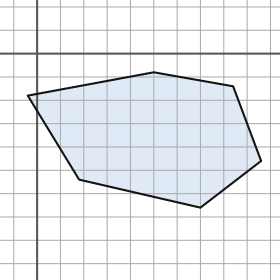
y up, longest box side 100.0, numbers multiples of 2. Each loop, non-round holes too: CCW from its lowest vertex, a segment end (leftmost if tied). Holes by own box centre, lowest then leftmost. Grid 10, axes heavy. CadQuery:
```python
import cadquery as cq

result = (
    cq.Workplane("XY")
    .moveTo(70.0, -66.0)
    .lineTo(96.0, -46.0)
    .lineTo(84.0, -14.0)
    .lineTo(50.0, -8.0)
    .lineTo(-4.0, -18.0)
    .lineTo(18.0, -54.0)
    .close()
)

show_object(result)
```